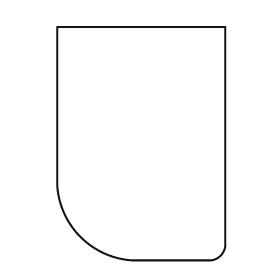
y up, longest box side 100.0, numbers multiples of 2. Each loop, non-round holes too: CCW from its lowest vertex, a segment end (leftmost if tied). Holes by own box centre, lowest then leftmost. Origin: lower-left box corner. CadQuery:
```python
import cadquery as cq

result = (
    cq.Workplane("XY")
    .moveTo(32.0, 0.0)
    .lineTo(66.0, 0.0)
    .threePointArc((70.0, 2.0), (72.0, 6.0))
    .lineTo(72.0, 100.0)
    .lineTo(0.0, 100.0)
    .lineTo(0.0, 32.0)
    .threePointArc((10.0, 10.0), (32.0, 0.0))
    .close()
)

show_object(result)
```